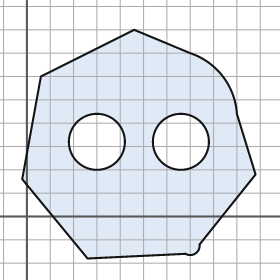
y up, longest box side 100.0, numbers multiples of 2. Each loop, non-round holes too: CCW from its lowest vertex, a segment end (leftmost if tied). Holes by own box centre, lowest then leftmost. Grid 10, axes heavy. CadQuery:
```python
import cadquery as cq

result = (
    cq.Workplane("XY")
    .moveTo(26.0, -18.0)
    .lineTo(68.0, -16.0)
    .threePointArc((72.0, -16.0), (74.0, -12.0))
    .lineTo(98.0, 18.0)
    .lineTo(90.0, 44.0)
    .threePointArc((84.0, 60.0), (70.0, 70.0))
    .lineTo(46.0, 80.0)
    .lineTo(6.0, 60.0)
    .lineTo(-2.0, 16.0)
    .close()
    .moveTo(30.0, 32.0)
    .circle(12.0)
    .moveTo(66.0, 32.0)
    .circle(12.0)
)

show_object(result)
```